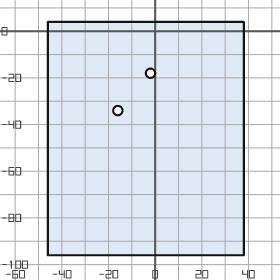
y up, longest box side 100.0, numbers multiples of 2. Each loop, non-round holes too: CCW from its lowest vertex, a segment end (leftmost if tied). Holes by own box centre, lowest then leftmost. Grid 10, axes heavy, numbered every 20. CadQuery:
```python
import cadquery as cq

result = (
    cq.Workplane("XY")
    .moveTo(-46.0, -96.0)
    .lineTo(38.0, -96.0)
    .lineTo(38.0, 4.0)
    .lineTo(-46.0, 4.0)
    .close()
    .moveTo(-16.0, -34.0)
    .circle(2.0)
    .moveTo(-2.0, -18.0)
    .circle(2.0)
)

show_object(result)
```